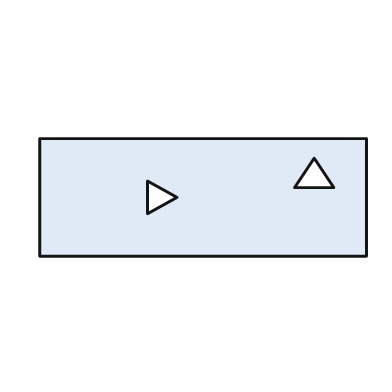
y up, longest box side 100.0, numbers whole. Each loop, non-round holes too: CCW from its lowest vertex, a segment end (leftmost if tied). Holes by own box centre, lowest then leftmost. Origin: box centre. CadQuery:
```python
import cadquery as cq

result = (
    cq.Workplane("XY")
    .moveTo(-50.0, -18.0)
    .lineTo(50.0, -18.0)
    .lineTo(50.0, 18.0)
    .lineTo(-50.0, 18.0)
    .close()
    .moveTo(-17.0, -5.0)
    .lineTo(-8.0, 0.0)
    .lineTo(-17.0, 5.0)
    .close()
    .moveTo(28.0, 3.0)
    .lineTo(40.0, 3.0)
    .lineTo(34.0, 12.0)
    .close()
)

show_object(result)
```